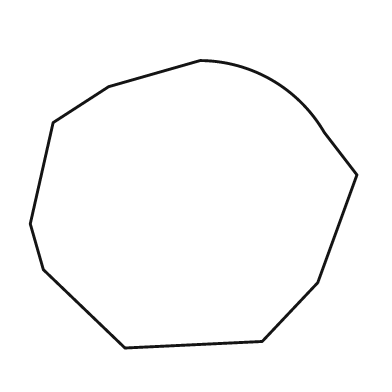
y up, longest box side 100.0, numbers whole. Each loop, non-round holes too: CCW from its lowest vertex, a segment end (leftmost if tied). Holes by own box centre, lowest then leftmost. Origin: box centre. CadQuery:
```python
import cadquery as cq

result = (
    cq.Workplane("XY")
    .moveTo(-21.0, -44.0)
    .lineTo(21.0, -42.0)
    .lineTo(38.0, -24.0)
    .lineTo(50.0, 9.0)
    .lineTo(40.0, 22.0)
    .threePointArc((24.0, 38.0), (2.0, 44.0))
    .lineTo(-26.0, 36.0)
    .lineTo(-43.0, 25.0)
    .lineTo(-50.0, -6.0)
    .lineTo(-46.0, -20.0)
    .close()
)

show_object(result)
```